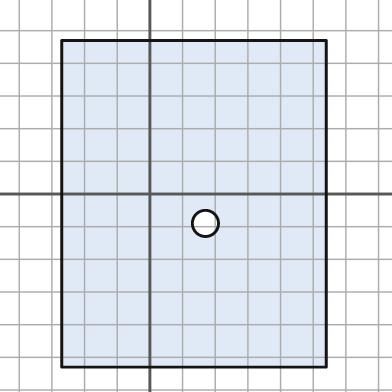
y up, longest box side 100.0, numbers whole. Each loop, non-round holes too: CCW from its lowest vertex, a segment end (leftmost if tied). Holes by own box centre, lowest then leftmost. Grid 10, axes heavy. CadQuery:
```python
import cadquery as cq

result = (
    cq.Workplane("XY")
    .moveTo(-27.0, -53.0)
    .lineTo(54.0, -53.0)
    .lineTo(54.0, 47.0)
    .lineTo(-27.0, 47.0)
    .close()
    .moveTo(17.0, -9.0)
    .circle(4.0)
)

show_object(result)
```